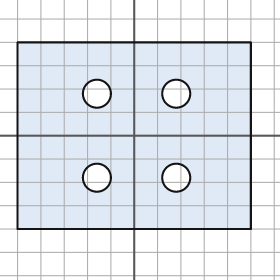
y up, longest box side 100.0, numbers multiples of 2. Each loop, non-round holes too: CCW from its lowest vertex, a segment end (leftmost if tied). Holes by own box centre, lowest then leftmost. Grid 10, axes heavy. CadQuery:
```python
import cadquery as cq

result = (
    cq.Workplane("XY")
    .moveTo(-50.0, -40.0)
    .lineTo(50.0, -40.0)
    .lineTo(50.0, 40.0)
    .lineTo(-50.0, 40.0)
    .close()
    .moveTo(-16.0, -18.0)
    .circle(6.0)
    .moveTo(18.0, -18.0)
    .circle(6.0)
    .moveTo(-16.0, 18.0)
    .circle(6.0)
    .moveTo(18.0, 18.0)
    .circle(6.0)
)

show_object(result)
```